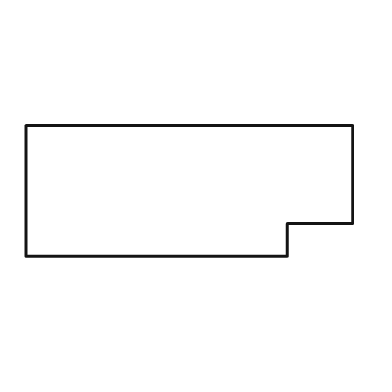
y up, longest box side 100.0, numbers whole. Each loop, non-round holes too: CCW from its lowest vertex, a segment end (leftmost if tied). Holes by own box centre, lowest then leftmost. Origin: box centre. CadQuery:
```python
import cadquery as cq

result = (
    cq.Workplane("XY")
    .moveTo(-50.0, -20.0)
    .lineTo(30.0, -20.0)
    .lineTo(30.0, -10.0)
    .lineTo(50.0, -10.0)
    .lineTo(50.0, 20.0)
    .lineTo(-50.0, 20.0)
    .close()
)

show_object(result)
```